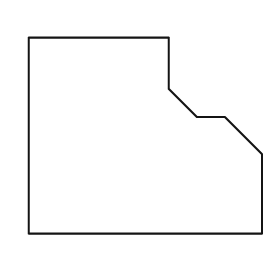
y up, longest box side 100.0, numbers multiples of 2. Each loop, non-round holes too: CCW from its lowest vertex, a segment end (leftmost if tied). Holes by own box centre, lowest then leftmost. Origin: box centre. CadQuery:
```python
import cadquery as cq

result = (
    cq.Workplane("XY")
    .moveTo(-50.0, -42.0)
    .lineTo(50.0, -42.0)
    .lineTo(50.0, -8.0)
    .lineTo(34.0, 8.0)
    .lineTo(22.0, 8.0)
    .lineTo(10.0, 20.0)
    .lineTo(10.0, 42.0)
    .lineTo(-50.0, 42.0)
    .close()
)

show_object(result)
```